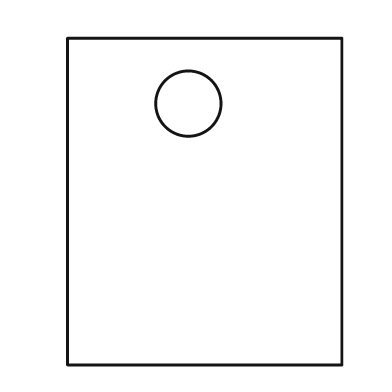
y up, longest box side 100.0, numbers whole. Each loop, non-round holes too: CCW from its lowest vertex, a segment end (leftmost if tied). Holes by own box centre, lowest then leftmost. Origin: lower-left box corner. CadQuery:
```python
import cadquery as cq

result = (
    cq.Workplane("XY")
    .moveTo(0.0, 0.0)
    .lineTo(84.0, 0.0)
    .lineTo(84.0, 100.0)
    .lineTo(0.0, 100.0)
    .close()
    .moveTo(37.0, 80.0)
    .circle(10.0)
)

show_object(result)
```